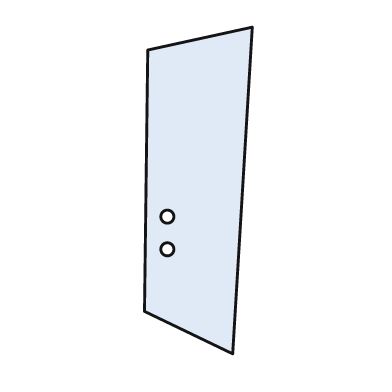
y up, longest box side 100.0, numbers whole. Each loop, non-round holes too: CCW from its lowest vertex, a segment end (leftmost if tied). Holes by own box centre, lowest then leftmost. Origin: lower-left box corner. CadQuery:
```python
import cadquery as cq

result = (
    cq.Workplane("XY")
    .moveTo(27.0, 0.0)
    .lineTo(33.0, 100.0)
    .lineTo(1.0, 93.0)
    .lineTo(0.0, 13.0)
    .close()
    .moveTo(7.0, 32.0)
    .circle(2.0)
    .moveTo(7.0, 42.0)
    .circle(2.0)
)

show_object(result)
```